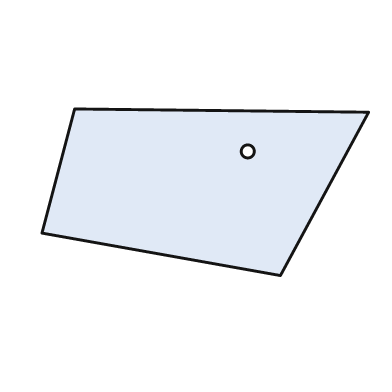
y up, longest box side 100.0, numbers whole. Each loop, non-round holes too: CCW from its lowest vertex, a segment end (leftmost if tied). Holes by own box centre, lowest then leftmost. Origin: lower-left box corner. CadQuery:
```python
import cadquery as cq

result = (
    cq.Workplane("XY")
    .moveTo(73.0, 0.0)
    .lineTo(100.0, 50.0)
    .lineTo(10.0, 51.0)
    .lineTo(0.0, 13.0)
    .close()
    .moveTo(63.0, 38.0)
    .circle(2.0)
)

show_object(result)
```